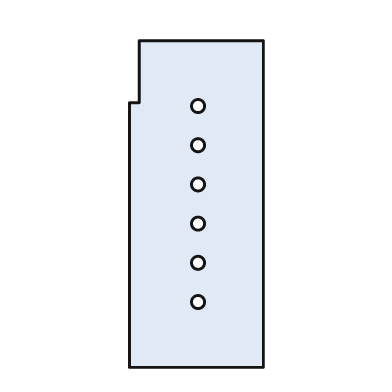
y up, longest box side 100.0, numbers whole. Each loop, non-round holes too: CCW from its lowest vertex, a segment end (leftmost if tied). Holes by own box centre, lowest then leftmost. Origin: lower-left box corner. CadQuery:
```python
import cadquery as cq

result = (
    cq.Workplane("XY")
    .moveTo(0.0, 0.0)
    .lineTo(41.0, 0.0)
    .lineTo(41.0, 100.0)
    .lineTo(3.0, 100.0)
    .lineTo(3.0, 81.0)
    .lineTo(0.0, 81.0)
    .close()
    .moveTo(21.0, 20.0)
    .circle(2.0)
    .moveTo(21.0, 32.0)
    .circle(2.0)
    .moveTo(21.0, 44.0)
    .circle(2.0)
    .moveTo(21.0, 56.0)
    .circle(2.0)
    .moveTo(21.0, 68.0)
    .circle(2.0)
    .moveTo(21.0, 80.0)
    .circle(2.0)
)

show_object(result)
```